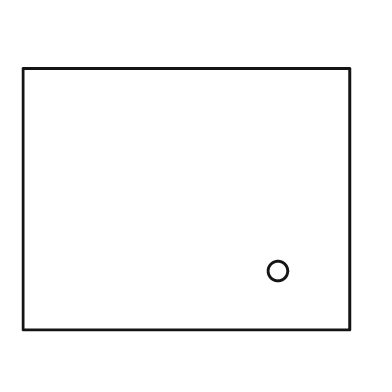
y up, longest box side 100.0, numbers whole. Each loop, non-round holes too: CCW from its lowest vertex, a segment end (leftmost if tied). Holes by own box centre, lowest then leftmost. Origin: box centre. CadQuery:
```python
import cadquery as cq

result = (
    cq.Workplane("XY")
    .moveTo(-50.0, -40.0)
    .lineTo(50.0, -40.0)
    .lineTo(50.0, 40.0)
    .lineTo(-50.0, 40.0)
    .close()
    .moveTo(28.0, -22.0)
    .circle(3.0)
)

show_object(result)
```